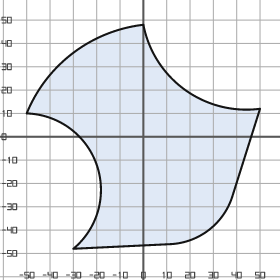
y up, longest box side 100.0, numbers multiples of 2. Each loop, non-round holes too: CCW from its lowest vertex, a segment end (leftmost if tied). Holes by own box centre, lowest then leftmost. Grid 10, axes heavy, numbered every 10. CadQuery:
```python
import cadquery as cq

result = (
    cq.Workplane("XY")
    .moveTo(-30.0, -48.0)
    .lineTo(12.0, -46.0)
    .threePointArc((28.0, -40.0), (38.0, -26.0))
    .lineTo(50.0, 12.0)
    .threePointArc((18.0, 20.0), (0.0, 48.0))
    .threePointArc((-30.0, 36.0), (-50.0, 10.0))
    .threePointArc((-20.0, -12.0), (-30.0, -48.0))
    .close()
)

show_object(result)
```